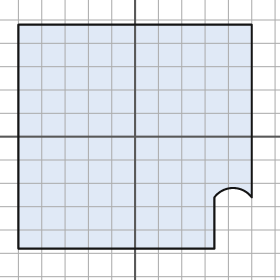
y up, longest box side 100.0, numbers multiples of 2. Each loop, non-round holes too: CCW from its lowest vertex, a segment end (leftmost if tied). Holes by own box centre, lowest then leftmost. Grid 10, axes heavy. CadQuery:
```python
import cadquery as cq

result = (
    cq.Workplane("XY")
    .moveTo(-50.0, -48.0)
    .lineTo(34.0, -48.0)
    .lineTo(34.0, -26.0)
    .threePointArc((42.0, -22.0), (50.0, -26.0))
    .lineTo(50.0, 48.0)
    .lineTo(-50.0, 48.0)
    .close()
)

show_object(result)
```